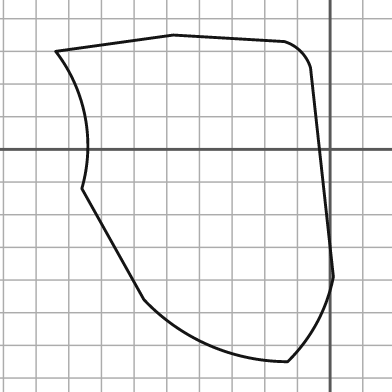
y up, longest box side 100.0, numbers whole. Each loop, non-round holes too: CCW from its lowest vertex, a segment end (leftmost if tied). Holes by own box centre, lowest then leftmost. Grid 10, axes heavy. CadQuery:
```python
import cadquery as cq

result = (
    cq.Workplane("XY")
    .moveTo(-13.0, -65.0)
    .threePointArc((-4.0, -53.0), (1.0, -39.0))
    .lineTo(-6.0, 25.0)
    .threePointArc((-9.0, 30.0), (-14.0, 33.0))
    .lineTo(-48.0, 35.0)
    .lineTo(-84.0, 30.0)
    .threePointArc((-75.0, 10.0), (-76.0, -12.0))
    .lineTo(-57.0, -46.0)
    .threePointArc((-37.0, -60.0), (-13.0, -65.0))
    .close()
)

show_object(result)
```